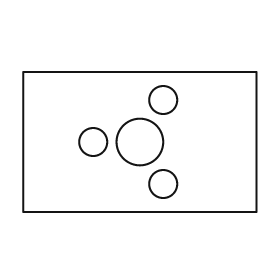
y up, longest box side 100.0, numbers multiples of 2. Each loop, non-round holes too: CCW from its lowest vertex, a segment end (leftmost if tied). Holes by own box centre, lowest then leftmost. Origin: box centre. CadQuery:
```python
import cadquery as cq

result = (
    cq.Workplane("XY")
    .moveTo(-50.0, -30.0)
    .lineTo(50.0, -30.0)
    .lineTo(50.0, 30.0)
    .lineTo(-50.0, 30.0)
    .close()
    .moveTo(10.0, -18.0)
    .circle(6.0)
    .moveTo(-20.0, 0.0)
    .circle(6.0)
    .moveTo(0.0, 0.0)
    .circle(10.0)
    .moveTo(10.0, 18.0)
    .circle(6.0)
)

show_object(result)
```